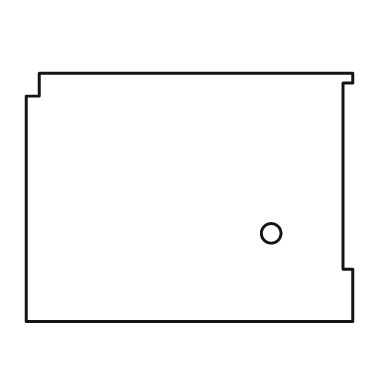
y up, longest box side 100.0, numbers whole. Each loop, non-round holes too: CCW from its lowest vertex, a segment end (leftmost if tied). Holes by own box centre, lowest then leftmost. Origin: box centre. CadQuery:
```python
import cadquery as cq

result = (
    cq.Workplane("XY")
    .moveTo(-50.0, -38.0)
    .lineTo(50.0, -38.0)
    .lineTo(50.0, -22.0)
    .lineTo(47.0, -22.0)
    .lineTo(47.0, 35.0)
    .lineTo(50.0, 35.0)
    .lineTo(50.0, 38.0)
    .lineTo(-46.0, 38.0)
    .lineTo(-46.0, 31.0)
    .lineTo(-50.0, 31.0)
    .close()
    .moveTo(25.0, -11.0)
    .circle(3.0)
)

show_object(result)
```